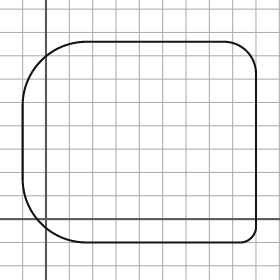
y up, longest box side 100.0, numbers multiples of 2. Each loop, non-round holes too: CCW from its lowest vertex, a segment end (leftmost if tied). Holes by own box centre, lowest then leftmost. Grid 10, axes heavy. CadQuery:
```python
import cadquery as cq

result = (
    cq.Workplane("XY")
    .moveTo(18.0, -10.0)
    .lineTo(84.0, -10.0)
    .threePointArc((88.0, -8.0), (90.0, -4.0))
    .lineTo(90.0, 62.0)
    .threePointArc((86.0, 72.0), (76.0, 76.0))
    .lineTo(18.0, 76.0)
    .threePointArc((-2.0, 68.0), (-10.0, 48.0))
    .lineTo(-10.0, 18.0)
    .threePointArc((-2.0, -2.0), (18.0, -10.0))
    .close()
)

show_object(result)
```